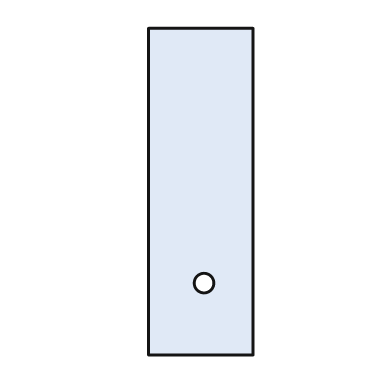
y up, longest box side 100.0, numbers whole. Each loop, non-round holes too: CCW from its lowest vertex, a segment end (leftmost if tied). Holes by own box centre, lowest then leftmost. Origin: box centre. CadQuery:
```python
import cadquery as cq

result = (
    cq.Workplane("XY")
    .moveTo(-16.0, -50.0)
    .lineTo(16.0, -50.0)
    .lineTo(16.0, 50.0)
    .lineTo(-16.0, 50.0)
    .close()
    .moveTo(1.0, -28.0)
    .circle(3.0)
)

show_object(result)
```